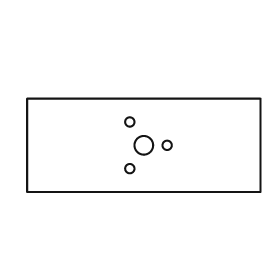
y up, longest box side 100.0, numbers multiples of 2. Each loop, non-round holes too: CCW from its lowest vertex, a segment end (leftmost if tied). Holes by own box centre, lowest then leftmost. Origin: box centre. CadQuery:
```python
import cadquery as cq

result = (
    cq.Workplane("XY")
    .moveTo(-50.0, -20.0)
    .lineTo(50.0, -20.0)
    .lineTo(50.0, 20.0)
    .lineTo(-50.0, 20.0)
    .close()
    .moveTo(-6.0, -10.0)
    .circle(2.0)
    .moveTo(0.0, 0.0)
    .circle(4.0)
    .moveTo(10.0, 0.0)
    .circle(2.0)
    .moveTo(-6.0, 10.0)
    .circle(2.0)
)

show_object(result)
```